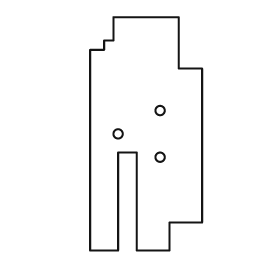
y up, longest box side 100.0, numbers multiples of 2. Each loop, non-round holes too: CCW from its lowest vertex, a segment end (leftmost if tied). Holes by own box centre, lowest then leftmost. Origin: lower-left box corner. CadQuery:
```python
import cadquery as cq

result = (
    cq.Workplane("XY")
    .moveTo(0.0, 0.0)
    .lineTo(12.0, 0.0)
    .lineTo(12.0, 42.0)
    .lineTo(20.0, 42.0)
    .lineTo(20.0, 0.0)
    .lineTo(34.0, 0.0)
    .lineTo(34.0, 12.0)
    .lineTo(48.0, 12.0)
    .lineTo(48.0, 78.0)
    .lineTo(38.0, 78.0)
    .lineTo(38.0, 100.0)
    .lineTo(10.0, 100.0)
    .lineTo(10.0, 90.0)
    .lineTo(6.0, 90.0)
    .lineTo(6.0, 86.0)
    .lineTo(0.0, 86.0)
    .close()
    .moveTo(30.0, 40.0)
    .circle(2.0)
    .moveTo(12.0, 50.0)
    .circle(2.0)
    .moveTo(30.0, 60.0)
    .circle(2.0)
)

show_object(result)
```